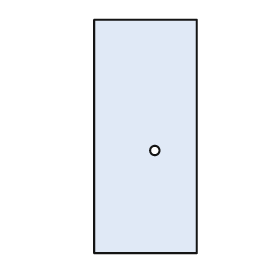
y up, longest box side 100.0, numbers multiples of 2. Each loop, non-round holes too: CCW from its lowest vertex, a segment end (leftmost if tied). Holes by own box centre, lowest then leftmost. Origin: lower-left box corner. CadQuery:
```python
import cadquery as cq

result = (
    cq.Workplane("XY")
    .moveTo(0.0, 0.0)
    .lineTo(44.0, 0.0)
    .lineTo(44.0, 100.0)
    .lineTo(0.0, 100.0)
    .close()
    .moveTo(26.0, 44.0)
    .circle(2.0)
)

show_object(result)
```